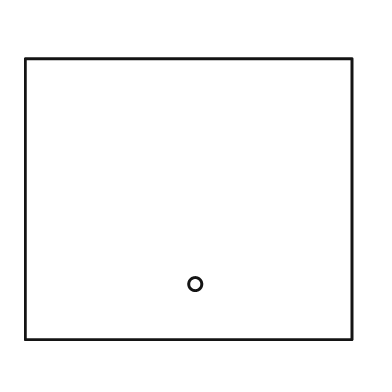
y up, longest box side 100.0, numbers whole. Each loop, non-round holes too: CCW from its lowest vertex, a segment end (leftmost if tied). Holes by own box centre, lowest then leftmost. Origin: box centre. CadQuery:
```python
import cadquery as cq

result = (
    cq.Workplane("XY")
    .moveTo(-50.0, -43.0)
    .lineTo(50.0, -43.0)
    .lineTo(50.0, 43.0)
    .lineTo(-50.0, 43.0)
    .close()
    .moveTo(2.0, -26.0)
    .circle(2.0)
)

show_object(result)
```